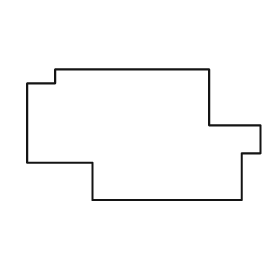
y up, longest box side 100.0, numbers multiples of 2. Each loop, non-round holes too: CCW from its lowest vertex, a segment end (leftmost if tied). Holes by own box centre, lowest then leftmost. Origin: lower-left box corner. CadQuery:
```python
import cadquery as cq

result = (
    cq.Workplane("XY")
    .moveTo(28.0, 0.0)
    .lineTo(92.0, 0.0)
    .lineTo(92.0, 20.0)
    .lineTo(100.0, 20.0)
    .lineTo(100.0, 32.0)
    .lineTo(78.0, 32.0)
    .lineTo(78.0, 56.0)
    .lineTo(12.0, 56.0)
    .lineTo(12.0, 50.0)
    .lineTo(0.0, 50.0)
    .lineTo(0.0, 16.0)
    .lineTo(28.0, 16.0)
    .close()
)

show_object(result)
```